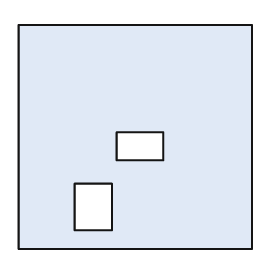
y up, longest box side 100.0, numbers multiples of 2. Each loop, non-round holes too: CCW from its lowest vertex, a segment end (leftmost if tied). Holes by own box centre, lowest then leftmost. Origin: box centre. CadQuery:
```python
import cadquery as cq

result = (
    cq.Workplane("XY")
    .moveTo(-50.0, -48.0)
    .lineTo(50.0, -48.0)
    .lineTo(50.0, 48.0)
    .lineTo(-50.0, 48.0)
    .close()
    .moveTo(-26.0, -40.0)
    .lineTo(-10.0, -40.0)
    .lineTo(-10.0, -20.0)
    .lineTo(-26.0, -20.0)
    .close()
    .moveTo(-8.0, -10.0)
    .lineTo(12.0, -10.0)
    .lineTo(12.0, 2.0)
    .lineTo(-8.0, 2.0)
    .close()
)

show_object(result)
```